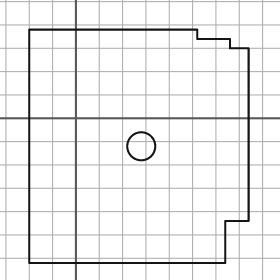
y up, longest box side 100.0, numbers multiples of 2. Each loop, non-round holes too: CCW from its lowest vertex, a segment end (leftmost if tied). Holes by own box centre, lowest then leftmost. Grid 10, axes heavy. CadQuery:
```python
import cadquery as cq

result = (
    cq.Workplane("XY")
    .moveTo(-20.0, -62.0)
    .lineTo(64.0, -62.0)
    .lineTo(64.0, -44.0)
    .lineTo(74.0, -44.0)
    .lineTo(74.0, 30.0)
    .lineTo(66.0, 30.0)
    .lineTo(66.0, 34.0)
    .lineTo(52.0, 34.0)
    .lineTo(52.0, 38.0)
    .lineTo(-20.0, 38.0)
    .close()
    .moveTo(28.0, -12.0)
    .circle(6.0)
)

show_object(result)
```